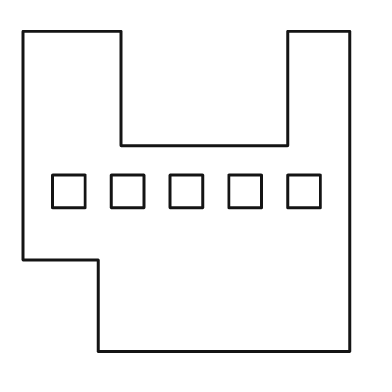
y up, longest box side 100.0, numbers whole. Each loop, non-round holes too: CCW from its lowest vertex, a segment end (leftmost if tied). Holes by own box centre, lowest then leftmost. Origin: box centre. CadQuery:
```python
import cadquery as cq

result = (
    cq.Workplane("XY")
    .moveTo(-27.0, -49.0)
    .lineTo(50.0, -49.0)
    .lineTo(50.0, 49.0)
    .lineTo(31.0, 49.0)
    .lineTo(31.0, 14.0)
    .lineTo(-20.0, 14.0)
    .lineTo(-20.0, 49.0)
    .lineTo(-50.0, 49.0)
    .lineTo(-50.0, -21.0)
    .lineTo(-27.0, -21.0)
    .close()
    .moveTo(-41.0, -5.0)
    .lineTo(-31.0, -5.0)
    .lineTo(-31.0, 5.0)
    .lineTo(-41.0, 5.0)
    .close()
    .moveTo(-23.0, -5.0)
    .lineTo(-13.0, -5.0)
    .lineTo(-13.0, 5.0)
    .lineTo(-23.0, 5.0)
    .close()
    .moveTo(-5.0, -5.0)
    .lineTo(5.0, -5.0)
    .lineTo(5.0, 5.0)
    .lineTo(-5.0, 5.0)
    .close()
    .moveTo(13.0, -5.0)
    .lineTo(23.0, -5.0)
    .lineTo(23.0, 5.0)
    .lineTo(13.0, 5.0)
    .close()
    .moveTo(31.0, -5.0)
    .lineTo(41.0, -5.0)
    .lineTo(41.0, 5.0)
    .lineTo(31.0, 5.0)
    .close()
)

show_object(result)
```